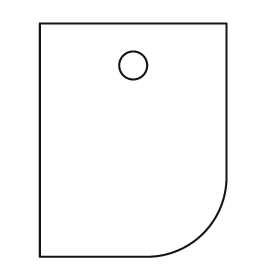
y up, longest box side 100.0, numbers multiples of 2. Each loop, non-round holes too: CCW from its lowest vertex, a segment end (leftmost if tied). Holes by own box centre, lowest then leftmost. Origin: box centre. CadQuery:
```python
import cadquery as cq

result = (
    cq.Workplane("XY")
    .moveTo(-40.0, -50.0)
    .lineTo(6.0, -50.0)
    .threePointArc((30.0, -40.0), (40.0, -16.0))
    .lineTo(40.0, 50.0)
    .lineTo(-40.0, 50.0)
    .close()
    .moveTo(0.0, 32.0)
    .circle(6.0)
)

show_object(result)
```